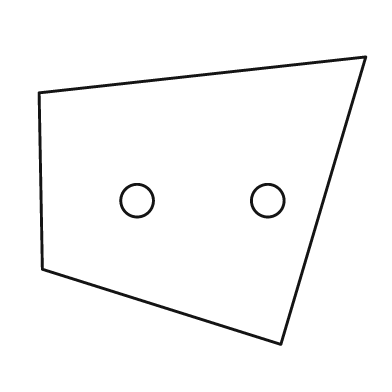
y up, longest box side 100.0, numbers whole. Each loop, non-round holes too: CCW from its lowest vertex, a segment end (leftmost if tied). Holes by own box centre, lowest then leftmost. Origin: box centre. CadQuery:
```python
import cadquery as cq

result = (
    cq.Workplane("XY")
    .moveTo(24.0, -44.0)
    .lineTo(50.0, 44.0)
    .lineTo(-50.0, 33.0)
    .lineTo(-49.0, -21.0)
    .close()
    .moveTo(-20.0, 0.0)
    .circle(5.0)
    .moveTo(20.0, 0.0)
    .circle(5.0)
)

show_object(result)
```